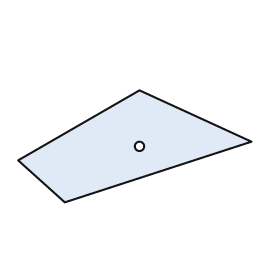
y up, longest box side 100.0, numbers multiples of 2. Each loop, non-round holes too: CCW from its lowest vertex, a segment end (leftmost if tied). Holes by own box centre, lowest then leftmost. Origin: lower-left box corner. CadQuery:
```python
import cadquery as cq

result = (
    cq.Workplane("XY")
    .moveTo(20.0, 0.0)
    .lineTo(100.0, 26.0)
    .lineTo(52.0, 48.0)
    .lineTo(0.0, 18.0)
    .close()
    .moveTo(52.0, 24.0)
    .circle(2.0)
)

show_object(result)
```